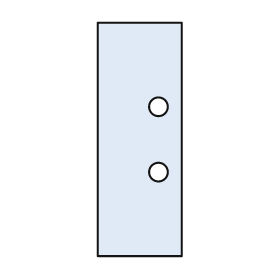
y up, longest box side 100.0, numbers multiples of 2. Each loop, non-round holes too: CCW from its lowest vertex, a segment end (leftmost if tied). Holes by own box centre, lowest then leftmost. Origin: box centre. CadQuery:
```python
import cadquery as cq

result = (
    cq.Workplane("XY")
    .moveTo(-18.0, -50.0)
    .lineTo(18.0, -50.0)
    .lineTo(18.0, 50.0)
    .lineTo(-18.0, 50.0)
    .close()
    .moveTo(8.0, -14.0)
    .circle(4.0)
    .moveTo(8.0, 14.0)
    .circle(4.0)
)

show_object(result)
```